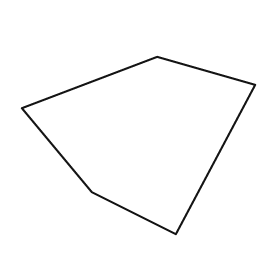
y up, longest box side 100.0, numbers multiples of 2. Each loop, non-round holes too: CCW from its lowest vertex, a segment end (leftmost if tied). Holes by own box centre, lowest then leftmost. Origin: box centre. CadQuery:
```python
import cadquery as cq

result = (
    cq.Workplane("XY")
    .moveTo(16.0, -38.0)
    .lineTo(50.0, 26.0)
    .lineTo(8.0, 38.0)
    .lineTo(-50.0, 16.0)
    .lineTo(-20.0, -20.0)
    .close()
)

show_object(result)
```